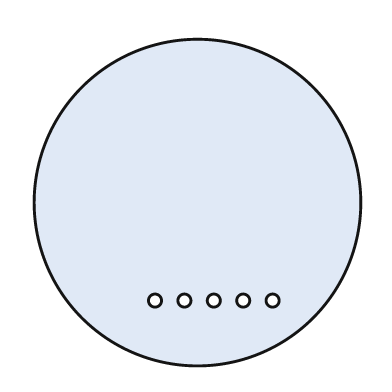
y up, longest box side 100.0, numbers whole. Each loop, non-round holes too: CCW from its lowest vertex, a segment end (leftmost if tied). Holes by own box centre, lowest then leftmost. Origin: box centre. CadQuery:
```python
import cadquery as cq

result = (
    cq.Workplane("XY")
    .moveTo(0.0, 0.0)
    .circle(50.0)
    .moveTo(-13.0, -30.0)
    .circle(2.0)
    .moveTo(-4.0, -30.0)
    .circle(2.0)
    .moveTo(5.0, -30.0)
    .circle(2.0)
    .moveTo(14.0, -30.0)
    .circle(2.0)
    .moveTo(23.0, -30.0)
    .circle(2.0)
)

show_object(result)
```